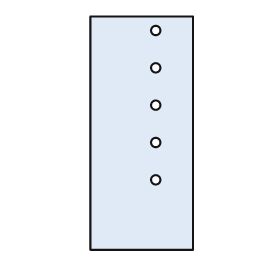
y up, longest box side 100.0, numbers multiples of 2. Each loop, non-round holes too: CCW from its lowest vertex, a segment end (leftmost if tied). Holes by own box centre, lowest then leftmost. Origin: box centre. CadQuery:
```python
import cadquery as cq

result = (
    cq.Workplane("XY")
    .moveTo(-22.0, -50.0)
    .lineTo(22.0, -50.0)
    .lineTo(22.0, 50.0)
    .lineTo(-22.0, 50.0)
    .close()
    .moveTo(6.0, -20.0)
    .circle(2.0)
    .moveTo(6.0, -4.0)
    .circle(2.0)
    .moveTo(6.0, 12.0)
    .circle(2.0)
    .moveTo(6.0, 28.0)
    .circle(2.0)
    .moveTo(6.0, 44.0)
    .circle(2.0)
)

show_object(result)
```